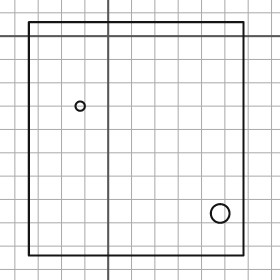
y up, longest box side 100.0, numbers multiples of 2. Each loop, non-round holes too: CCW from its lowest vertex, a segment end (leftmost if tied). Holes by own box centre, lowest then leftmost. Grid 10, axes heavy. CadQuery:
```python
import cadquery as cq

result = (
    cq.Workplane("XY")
    .moveTo(-34.0, -94.0)
    .lineTo(58.0, -94.0)
    .lineTo(58.0, 6.0)
    .lineTo(-34.0, 6.0)
    .close()
    .moveTo(48.0, -76.0)
    .circle(4.0)
    .moveTo(-12.0, -30.0)
    .circle(2.0)
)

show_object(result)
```